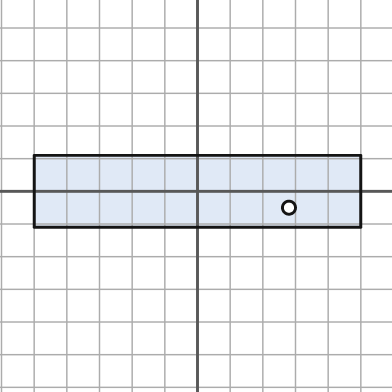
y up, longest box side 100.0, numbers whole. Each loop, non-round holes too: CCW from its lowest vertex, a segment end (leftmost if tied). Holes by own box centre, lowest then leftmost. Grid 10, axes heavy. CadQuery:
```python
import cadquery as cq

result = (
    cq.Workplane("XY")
    .moveTo(-50.0, -11.0)
    .lineTo(50.0, -11.0)
    .lineTo(50.0, 11.0)
    .lineTo(-50.0, 11.0)
    .close()
    .moveTo(28.0, -5.0)
    .circle(2.0)
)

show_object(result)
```